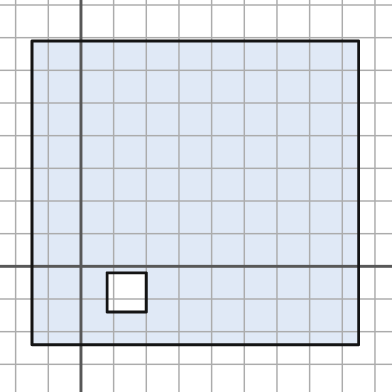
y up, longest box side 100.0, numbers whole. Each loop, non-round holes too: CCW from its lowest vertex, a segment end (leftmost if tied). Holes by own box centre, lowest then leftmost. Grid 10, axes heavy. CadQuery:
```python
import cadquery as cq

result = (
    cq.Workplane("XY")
    .moveTo(-15.0, -24.0)
    .lineTo(85.0, -24.0)
    .lineTo(85.0, 69.0)
    .lineTo(-15.0, 69.0)
    .close()
    .moveTo(8.0, -14.0)
    .lineTo(20.0, -14.0)
    .lineTo(20.0, -2.0)
    .lineTo(8.0, -2.0)
    .close()
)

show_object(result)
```